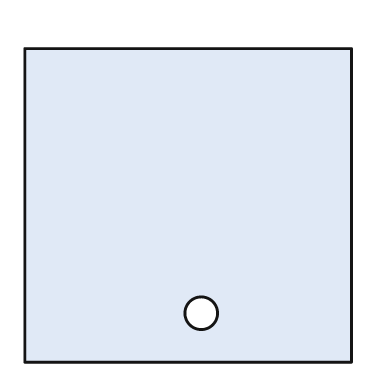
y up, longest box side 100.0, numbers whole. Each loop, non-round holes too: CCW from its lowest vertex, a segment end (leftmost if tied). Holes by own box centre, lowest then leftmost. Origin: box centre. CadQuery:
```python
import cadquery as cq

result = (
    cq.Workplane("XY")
    .moveTo(-50.0, -48.0)
    .lineTo(50.0, -48.0)
    .lineTo(50.0, 48.0)
    .lineTo(-50.0, 48.0)
    .close()
    .moveTo(4.0, -33.0)
    .circle(5.0)
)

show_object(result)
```